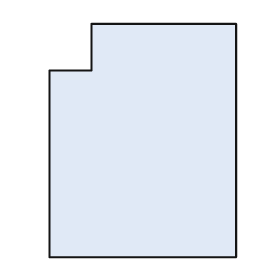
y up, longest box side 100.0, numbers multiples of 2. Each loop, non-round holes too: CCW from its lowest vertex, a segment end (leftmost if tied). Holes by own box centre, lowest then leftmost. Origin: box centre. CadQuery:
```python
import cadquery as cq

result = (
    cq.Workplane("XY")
    .moveTo(-40.0, -50.0)
    .lineTo(40.0, -50.0)
    .lineTo(40.0, 50.0)
    .lineTo(-22.0, 50.0)
    .lineTo(-22.0, 30.0)
    .lineTo(-40.0, 30.0)
    .close()
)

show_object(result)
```